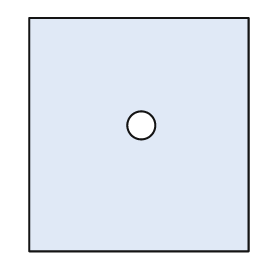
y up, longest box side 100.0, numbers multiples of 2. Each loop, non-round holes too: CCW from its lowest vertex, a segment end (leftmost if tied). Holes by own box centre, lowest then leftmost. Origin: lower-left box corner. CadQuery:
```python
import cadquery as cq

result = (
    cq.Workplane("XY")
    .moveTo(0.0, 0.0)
    .lineTo(94.0, 0.0)
    .lineTo(94.0, 100.0)
    .lineTo(0.0, 100.0)
    .close()
    .moveTo(48.0, 54.0)
    .circle(6.0)
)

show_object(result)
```